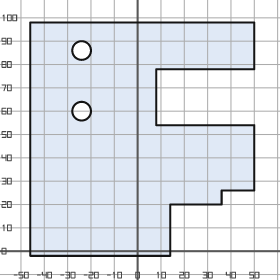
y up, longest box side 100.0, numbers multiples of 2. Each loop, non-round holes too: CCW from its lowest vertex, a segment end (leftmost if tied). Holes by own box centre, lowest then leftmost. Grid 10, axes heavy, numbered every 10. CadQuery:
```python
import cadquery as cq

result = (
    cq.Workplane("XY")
    .moveTo(-46.0, -2.0)
    .lineTo(14.0, -2.0)
    .lineTo(14.0, 20.0)
    .lineTo(36.0, 20.0)
    .lineTo(36.0, 26.0)
    .lineTo(50.0, 26.0)
    .lineTo(50.0, 54.0)
    .lineTo(8.0, 54.0)
    .lineTo(8.0, 78.0)
    .lineTo(50.0, 78.0)
    .lineTo(50.0, 98.0)
    .lineTo(-46.0, 98.0)
    .close()
    .moveTo(-24.0, 60.0)
    .circle(4.0)
    .moveTo(-24.0, 86.0)
    .circle(4.0)
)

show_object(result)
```